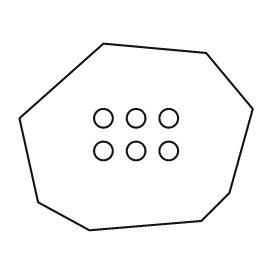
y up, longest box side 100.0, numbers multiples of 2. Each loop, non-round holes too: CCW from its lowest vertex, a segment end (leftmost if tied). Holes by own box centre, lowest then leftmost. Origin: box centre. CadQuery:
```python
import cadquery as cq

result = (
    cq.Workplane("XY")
    .moveTo(-20.0, -40.0)
    .lineTo(28.0, -36.0)
    .lineTo(40.0, -24.0)
    .lineTo(50.0, 12.0)
    .lineTo(30.0, 36.0)
    .lineTo(-14.0, 40.0)
    .lineTo(-50.0, 8.0)
    .lineTo(-42.0, -28.0)
    .close()
    .moveTo(-14.0, -6.0)
    .circle(4.0)
    .moveTo(0.0, -6.0)
    .circle(4.0)
    .moveTo(14.0, -6.0)
    .circle(4.0)
    .moveTo(-14.0, 8.0)
    .circle(4.0)
    .moveTo(0.0, 8.0)
    .circle(4.0)
    .moveTo(14.0, 8.0)
    .circle(4.0)
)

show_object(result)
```